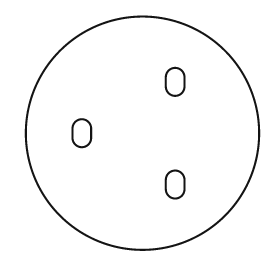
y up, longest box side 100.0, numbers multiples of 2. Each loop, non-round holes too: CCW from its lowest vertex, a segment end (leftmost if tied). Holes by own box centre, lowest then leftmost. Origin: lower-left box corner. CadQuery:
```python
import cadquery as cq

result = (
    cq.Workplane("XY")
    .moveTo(50.0, 50.0)
    .circle(50.0)
    .moveTo(60.0, 26.0)
    .threePointArc((64.0, 22.0), (68.0, 26.0))
    .lineTo(68.0, 30.0)
    .threePointArc((64.0, 34.0), (60.0, 30.0))
    .close()
    .moveTo(20.0, 48.0)
    .threePointArc((24.0, 44.0), (28.0, 48.0))
    .lineTo(28.0, 52.0)
    .threePointArc((24.0, 56.0), (20.0, 52.0))
    .close()
    .moveTo(60.0, 70.0)
    .threePointArc((64.0, 66.0), (68.0, 70.0))
    .lineTo(68.0, 74.0)
    .threePointArc((64.0, 78.0), (60.0, 74.0))
    .close()
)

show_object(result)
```